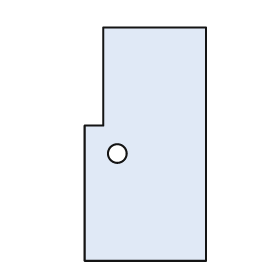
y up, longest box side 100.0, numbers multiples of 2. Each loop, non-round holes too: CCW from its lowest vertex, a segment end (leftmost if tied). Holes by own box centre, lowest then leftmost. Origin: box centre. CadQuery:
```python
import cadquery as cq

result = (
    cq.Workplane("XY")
    .moveTo(-26.0, -50.0)
    .lineTo(26.0, -50.0)
    .lineTo(26.0, 50.0)
    .lineTo(-18.0, 50.0)
    .lineTo(-18.0, 8.0)
    .lineTo(-26.0, 8.0)
    .close()
    .moveTo(-12.0, -4.0)
    .circle(4.0)
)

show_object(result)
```